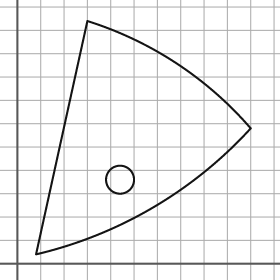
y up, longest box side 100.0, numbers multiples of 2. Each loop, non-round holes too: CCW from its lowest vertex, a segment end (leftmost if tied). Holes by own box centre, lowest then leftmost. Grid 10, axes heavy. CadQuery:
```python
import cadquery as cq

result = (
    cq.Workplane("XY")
    .moveTo(8.0, 4.0)
    .threePointArc((58.0, 24.0), (100.0, 58.0))
    .threePointArc((68.0, 86.0), (30.0, 104.0))
    .close()
    .moveTo(44.0, 36.0)
    .circle(6.0)
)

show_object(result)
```